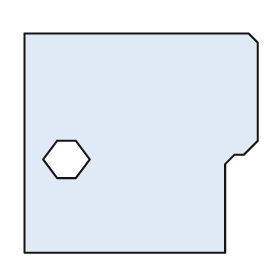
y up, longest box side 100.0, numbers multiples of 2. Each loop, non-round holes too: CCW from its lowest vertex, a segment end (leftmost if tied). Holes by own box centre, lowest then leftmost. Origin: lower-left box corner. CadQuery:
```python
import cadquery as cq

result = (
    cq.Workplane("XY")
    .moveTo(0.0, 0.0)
    .lineTo(86.0, 0.0)
    .lineTo(86.0, 38.0)
    .lineTo(90.0, 42.0)
    .lineTo(94.0, 42.0)
    .lineTo(100.0, 48.0)
    .lineTo(100.0, 90.0)
    .lineTo(96.0, 94.0)
    .lineTo(0.0, 94.0)
    .close()
    .moveTo(14.0, 32.0)
    .lineTo(22.0, 32.0)
    .lineTo(28.0, 40.0)
    .lineTo(22.0, 48.0)
    .lineTo(14.0, 48.0)
    .lineTo(8.0, 40.0)
    .close()
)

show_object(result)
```